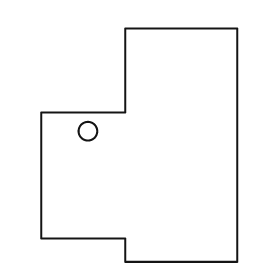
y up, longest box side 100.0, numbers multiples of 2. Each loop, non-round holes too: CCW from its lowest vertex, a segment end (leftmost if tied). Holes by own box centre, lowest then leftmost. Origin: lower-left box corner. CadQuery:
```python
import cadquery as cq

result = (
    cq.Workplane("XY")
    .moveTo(36.0, 0.0)
    .lineTo(84.0, 0.0)
    .lineTo(84.0, 100.0)
    .lineTo(36.0, 100.0)
    .lineTo(36.0, 64.0)
    .lineTo(0.0, 64.0)
    .lineTo(0.0, 10.0)
    .lineTo(36.0, 10.0)
    .close()
    .moveTo(20.0, 56.0)
    .circle(4.0)
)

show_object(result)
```